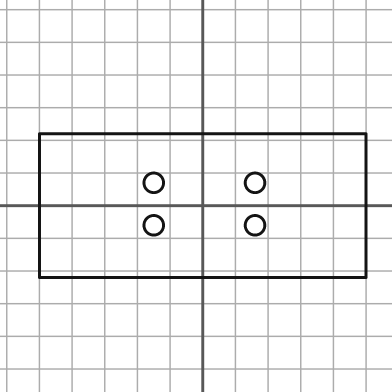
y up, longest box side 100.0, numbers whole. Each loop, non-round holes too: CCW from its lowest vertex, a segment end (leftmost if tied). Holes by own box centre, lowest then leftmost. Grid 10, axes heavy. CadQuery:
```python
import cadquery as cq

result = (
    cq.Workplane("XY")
    .moveTo(-50.0, -22.0)
    .lineTo(50.0, -22.0)
    .lineTo(50.0, 22.0)
    .lineTo(-50.0, 22.0)
    .close()
    .moveTo(-15.0, -6.0)
    .circle(3.0)
    .moveTo(16.0, -6.0)
    .circle(3.0)
    .moveTo(-15.0, 7.0)
    .circle(3.0)
    .moveTo(16.0, 7.0)
    .circle(3.0)
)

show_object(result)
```